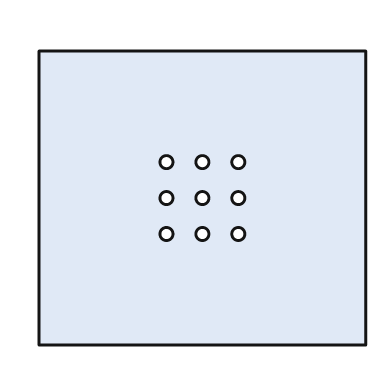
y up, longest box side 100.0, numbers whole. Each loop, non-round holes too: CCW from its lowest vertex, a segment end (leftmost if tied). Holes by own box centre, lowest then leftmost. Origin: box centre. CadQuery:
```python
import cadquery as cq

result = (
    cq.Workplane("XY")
    .moveTo(-50.0, -45.0)
    .lineTo(50.0, -45.0)
    .lineTo(50.0, 45.0)
    .lineTo(-50.0, 45.0)
    .close()
    .moveTo(-11.0, -11.0)
    .circle(2.0)
    .moveTo(0.0, -11.0)
    .circle(2.0)
    .moveTo(11.0, -11.0)
    .circle(2.0)
    .moveTo(-11.0, 0.0)
    .circle(2.0)
    .moveTo(0.0, 0.0)
    .circle(2.0)
    .moveTo(11.0, 0.0)
    .circle(2.0)
    .moveTo(-11.0, 11.0)
    .circle(2.0)
    .moveTo(0.0, 11.0)
    .circle(2.0)
    .moveTo(11.0, 11.0)
    .circle(2.0)
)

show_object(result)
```